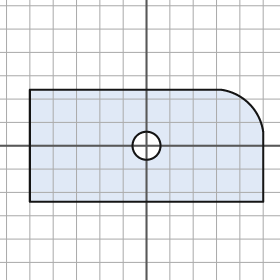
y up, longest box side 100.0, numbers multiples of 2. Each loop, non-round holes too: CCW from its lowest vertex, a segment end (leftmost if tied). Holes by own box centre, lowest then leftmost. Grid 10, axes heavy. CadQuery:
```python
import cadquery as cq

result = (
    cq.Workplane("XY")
    .moveTo(-50.0, -24.0)
    .lineTo(50.0, -24.0)
    .lineTo(50.0, 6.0)
    .threePointArc((44.0, 18.0), (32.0, 24.0))
    .lineTo(-50.0, 24.0)
    .close()
    .moveTo(0.0, 0.0)
    .circle(6.0)
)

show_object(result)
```